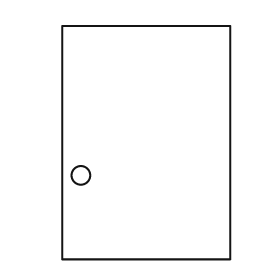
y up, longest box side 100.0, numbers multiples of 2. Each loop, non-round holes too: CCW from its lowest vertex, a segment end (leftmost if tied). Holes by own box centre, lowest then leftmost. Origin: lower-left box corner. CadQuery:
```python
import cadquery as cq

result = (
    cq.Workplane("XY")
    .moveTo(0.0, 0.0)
    .lineTo(72.0, 0.0)
    .lineTo(72.0, 100.0)
    .lineTo(0.0, 100.0)
    .close()
    .moveTo(8.0, 36.0)
    .circle(4.0)
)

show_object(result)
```